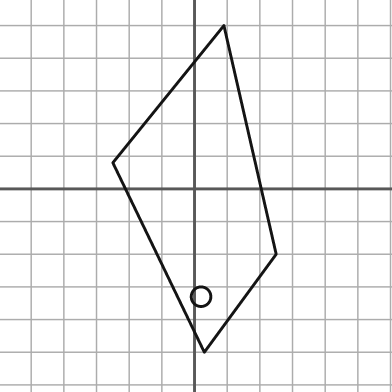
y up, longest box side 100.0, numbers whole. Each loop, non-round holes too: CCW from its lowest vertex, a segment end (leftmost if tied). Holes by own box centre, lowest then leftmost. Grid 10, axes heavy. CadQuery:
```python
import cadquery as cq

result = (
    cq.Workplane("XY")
    .moveTo(3.0, -50.0)
    .lineTo(25.0, -20.0)
    .lineTo(9.0, 50.0)
    .lineTo(-25.0, 8.0)
    .close()
    .moveTo(2.0, -33.0)
    .circle(3.0)
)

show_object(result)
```